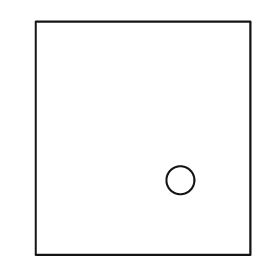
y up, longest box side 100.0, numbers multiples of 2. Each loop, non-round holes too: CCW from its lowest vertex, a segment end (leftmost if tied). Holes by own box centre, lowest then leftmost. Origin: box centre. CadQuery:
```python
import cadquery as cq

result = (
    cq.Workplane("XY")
    .moveTo(-46.0, -50.0)
    .lineTo(46.0, -50.0)
    .lineTo(46.0, 50.0)
    .lineTo(-46.0, 50.0)
    .close()
    .moveTo(16.0, -18.0)
    .circle(6.0)
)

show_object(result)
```